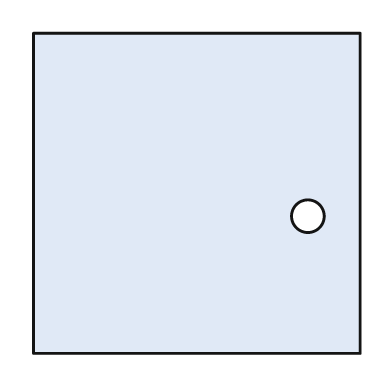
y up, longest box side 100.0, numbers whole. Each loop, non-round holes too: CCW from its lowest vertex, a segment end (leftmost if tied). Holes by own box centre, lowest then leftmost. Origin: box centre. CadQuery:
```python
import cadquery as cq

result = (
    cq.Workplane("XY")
    .moveTo(-50.0, -49.0)
    .lineTo(50.0, -49.0)
    .lineTo(50.0, 49.0)
    .lineTo(-50.0, 49.0)
    .close()
    .moveTo(34.0, -7.0)
    .circle(5.0)
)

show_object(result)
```